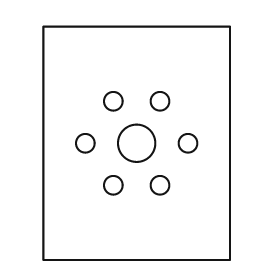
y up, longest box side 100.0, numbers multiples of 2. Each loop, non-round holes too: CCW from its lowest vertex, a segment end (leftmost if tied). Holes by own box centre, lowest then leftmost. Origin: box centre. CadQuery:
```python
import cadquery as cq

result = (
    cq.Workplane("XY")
    .moveTo(-40.0, -50.0)
    .lineTo(40.0, -50.0)
    .lineTo(40.0, 50.0)
    .lineTo(-40.0, 50.0)
    .close()
    .moveTo(-10.0, -18.0)
    .circle(4.0)
    .moveTo(10.0, -18.0)
    .circle(4.0)
    .moveTo(-22.0, 0.0)
    .circle(4.0)
    .moveTo(0.0, 0.0)
    .circle(8.0)
    .moveTo(22.0, 0.0)
    .circle(4.0)
    .moveTo(-10.0, 18.0)
    .circle(4.0)
    .moveTo(10.0, 18.0)
    .circle(4.0)
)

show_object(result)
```